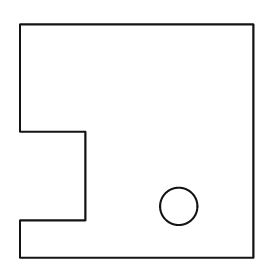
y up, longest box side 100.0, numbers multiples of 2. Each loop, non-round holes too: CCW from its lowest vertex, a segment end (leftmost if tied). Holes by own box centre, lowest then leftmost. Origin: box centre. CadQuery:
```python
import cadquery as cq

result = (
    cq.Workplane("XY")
    .moveTo(-50.0, -50.0)
    .lineTo(50.0, -50.0)
    .lineTo(50.0, 50.0)
    .lineTo(-50.0, 50.0)
    .lineTo(-50.0, 4.0)
    .lineTo(-22.0, 4.0)
    .lineTo(-22.0, -34.0)
    .lineTo(-50.0, -34.0)
    .close()
    .moveTo(18.0, -28.0)
    .circle(8.0)
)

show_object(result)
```